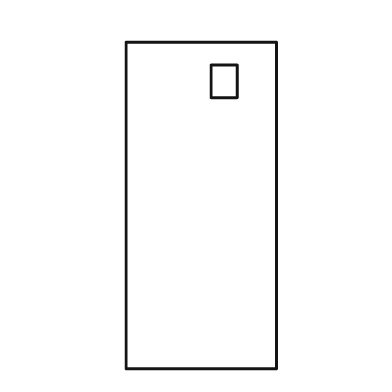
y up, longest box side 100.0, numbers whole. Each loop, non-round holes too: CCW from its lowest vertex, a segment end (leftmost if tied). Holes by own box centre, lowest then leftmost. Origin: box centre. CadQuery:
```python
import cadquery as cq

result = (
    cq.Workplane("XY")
    .moveTo(-23.0, -50.0)
    .lineTo(23.0, -50.0)
    .lineTo(23.0, 50.0)
    .lineTo(-23.0, 50.0)
    .close()
    .moveTo(3.0, 33.0)
    .lineTo(11.0, 33.0)
    .lineTo(11.0, 43.0)
    .lineTo(3.0, 43.0)
    .close()
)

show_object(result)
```